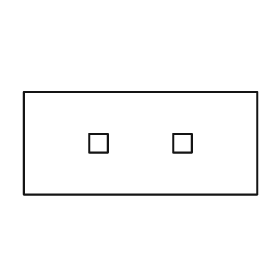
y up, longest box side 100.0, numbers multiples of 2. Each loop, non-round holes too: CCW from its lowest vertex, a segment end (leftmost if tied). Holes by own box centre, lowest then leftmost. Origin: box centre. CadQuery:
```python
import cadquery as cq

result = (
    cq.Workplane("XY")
    .moveTo(-50.0, -22.0)
    .lineTo(50.0, -22.0)
    .lineTo(50.0, 22.0)
    .lineTo(-50.0, 22.0)
    .close()
    .moveTo(-22.0, -4.0)
    .lineTo(-14.0, -4.0)
    .lineTo(-14.0, 4.0)
    .lineTo(-22.0, 4.0)
    .close()
    .moveTo(14.0, -4.0)
    .lineTo(22.0, -4.0)
    .lineTo(22.0, 4.0)
    .lineTo(14.0, 4.0)
    .close()
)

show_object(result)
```